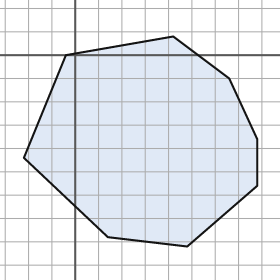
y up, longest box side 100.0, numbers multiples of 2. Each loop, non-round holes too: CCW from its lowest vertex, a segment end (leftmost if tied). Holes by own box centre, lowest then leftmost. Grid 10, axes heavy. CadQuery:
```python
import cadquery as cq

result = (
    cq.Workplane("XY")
    .moveTo(48.0, -82.0)
    .lineTo(78.0, -56.0)
    .lineTo(78.0, -36.0)
    .lineTo(66.0, -10.0)
    .lineTo(42.0, 8.0)
    .lineTo(-4.0, 0.0)
    .lineTo(-22.0, -44.0)
    .lineTo(14.0, -78.0)
    .close()
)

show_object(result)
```